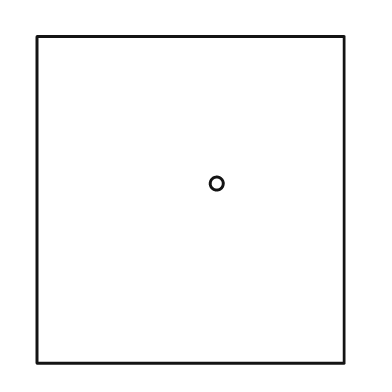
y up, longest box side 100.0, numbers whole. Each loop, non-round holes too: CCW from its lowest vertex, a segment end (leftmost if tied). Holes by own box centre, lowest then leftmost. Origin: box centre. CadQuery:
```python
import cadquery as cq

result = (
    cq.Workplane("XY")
    .moveTo(-47.0, -50.0)
    .lineTo(47.0, -50.0)
    .lineTo(47.0, 50.0)
    .lineTo(-47.0, 50.0)
    .close()
    .moveTo(8.0, 5.0)
    .circle(2.0)
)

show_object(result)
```